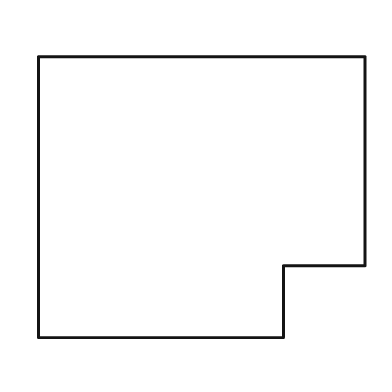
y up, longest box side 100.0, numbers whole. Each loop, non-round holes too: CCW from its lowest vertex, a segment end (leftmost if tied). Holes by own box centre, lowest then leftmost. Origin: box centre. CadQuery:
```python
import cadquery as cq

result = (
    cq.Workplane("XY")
    .moveTo(-50.0, -43.0)
    .lineTo(25.0, -43.0)
    .lineTo(25.0, -21.0)
    .lineTo(50.0, -21.0)
    .lineTo(50.0, 43.0)
    .lineTo(-50.0, 43.0)
    .close()
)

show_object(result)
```